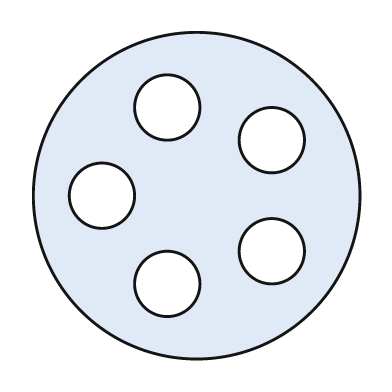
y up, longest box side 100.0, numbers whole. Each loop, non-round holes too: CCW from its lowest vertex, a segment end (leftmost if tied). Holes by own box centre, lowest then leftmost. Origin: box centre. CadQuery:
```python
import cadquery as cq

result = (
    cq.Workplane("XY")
    .moveTo(0.0, 0.0)
    .circle(50.0)
    .moveTo(-9.0, -27.0)
    .circle(10.0)
    .moveTo(23.0, -17.0)
    .circle(10.0)
    .moveTo(-29.0, 0.0)
    .circle(10.0)
    .moveTo(23.0, 17.0)
    .circle(10.0)
    .moveTo(-9.0, 27.0)
    .circle(10.0)
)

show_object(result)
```